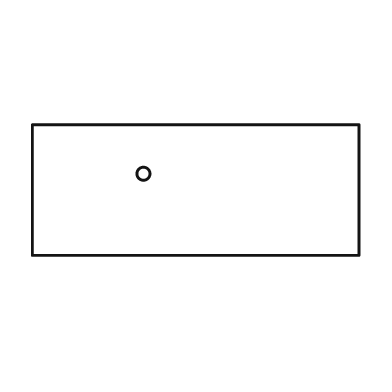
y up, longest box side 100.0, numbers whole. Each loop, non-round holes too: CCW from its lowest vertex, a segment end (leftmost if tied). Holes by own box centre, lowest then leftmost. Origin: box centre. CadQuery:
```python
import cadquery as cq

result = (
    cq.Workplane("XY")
    .moveTo(-50.0, -20.0)
    .lineTo(50.0, -20.0)
    .lineTo(50.0, 20.0)
    .lineTo(-50.0, 20.0)
    .close()
    .moveTo(-16.0, 5.0)
    .circle(2.0)
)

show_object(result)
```